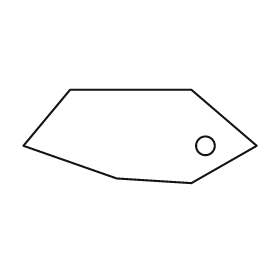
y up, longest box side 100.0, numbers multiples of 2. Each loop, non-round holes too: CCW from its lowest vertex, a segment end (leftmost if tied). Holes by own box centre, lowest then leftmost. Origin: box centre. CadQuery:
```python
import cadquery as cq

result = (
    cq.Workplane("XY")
    .moveTo(22.0, -20.0)
    .lineTo(50.0, -4.0)
    .lineTo(22.0, 20.0)
    .lineTo(-30.0, 20.0)
    .lineTo(-50.0, -4.0)
    .lineTo(-10.0, -18.0)
    .close()
    .moveTo(28.0, -4.0)
    .circle(4.0)
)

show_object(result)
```